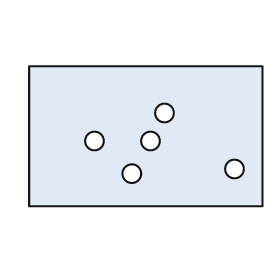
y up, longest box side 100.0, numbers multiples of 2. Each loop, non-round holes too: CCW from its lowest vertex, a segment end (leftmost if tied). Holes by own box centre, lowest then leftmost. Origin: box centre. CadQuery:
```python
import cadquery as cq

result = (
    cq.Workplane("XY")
    .moveTo(-50.0, -30.0)
    .lineTo(50.0, -30.0)
    .lineTo(50.0, 30.0)
    .lineTo(-50.0, 30.0)
    .close()
    .moveTo(-6.0, -16.0)
    .circle(4.0)
    .moveTo(38.0, -14.0)
    .circle(4.0)
    .moveTo(-22.0, -2.0)
    .circle(4.0)
    .moveTo(2.0, -2.0)
    .circle(4.0)
    .moveTo(8.0, 10.0)
    .circle(4.0)
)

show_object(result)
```